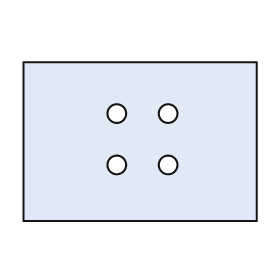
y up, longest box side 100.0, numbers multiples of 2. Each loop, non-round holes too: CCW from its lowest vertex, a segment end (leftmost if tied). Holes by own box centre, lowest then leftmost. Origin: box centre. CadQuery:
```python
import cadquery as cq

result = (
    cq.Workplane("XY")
    .moveTo(-50.0, -34.0)
    .lineTo(50.0, -34.0)
    .lineTo(50.0, 34.0)
    .lineTo(-50.0, 34.0)
    .close()
    .moveTo(-10.0, -10.0)
    .circle(4.0)
    .moveTo(12.0, -10.0)
    .circle(4.0)
    .moveTo(-10.0, 12.0)
    .circle(4.0)
    .moveTo(12.0, 12.0)
    .circle(4.0)
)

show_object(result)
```